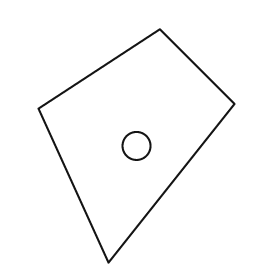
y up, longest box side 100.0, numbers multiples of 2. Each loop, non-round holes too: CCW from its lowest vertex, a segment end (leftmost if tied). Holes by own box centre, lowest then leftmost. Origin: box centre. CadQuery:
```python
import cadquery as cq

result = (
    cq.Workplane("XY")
    .moveTo(-12.0, -50.0)
    .lineTo(42.0, 18.0)
    .lineTo(10.0, 50.0)
    .lineTo(-42.0, 16.0)
    .close()
    .moveTo(0.0, 0.0)
    .circle(6.0)
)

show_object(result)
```